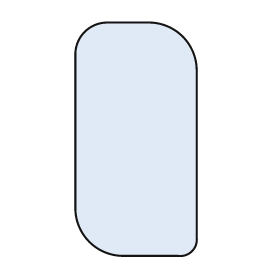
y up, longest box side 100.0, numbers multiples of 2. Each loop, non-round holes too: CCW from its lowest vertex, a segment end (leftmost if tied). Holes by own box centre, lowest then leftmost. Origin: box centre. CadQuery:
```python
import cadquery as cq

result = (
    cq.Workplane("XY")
    .moveTo(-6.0, -50.0)
    .lineTo(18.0, -50.0)
    .threePointArc((24.0, -48.0), (26.0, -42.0))
    .lineTo(26.0, 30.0)
    .threePointArc((20.0, 44.0), (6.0, 50.0))
    .lineTo(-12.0, 50.0)
    .threePointArc((-22.0, 46.0), (-26.0, 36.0))
    .lineTo(-26.0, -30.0)
    .threePointArc((-20.0, -44.0), (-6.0, -50.0))
    .close()
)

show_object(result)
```